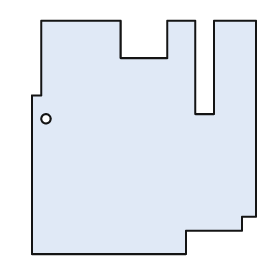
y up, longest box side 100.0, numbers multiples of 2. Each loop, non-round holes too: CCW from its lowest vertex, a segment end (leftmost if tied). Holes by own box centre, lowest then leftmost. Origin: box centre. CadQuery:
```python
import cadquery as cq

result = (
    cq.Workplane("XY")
    .moveTo(-48.0, -50.0)
    .lineTo(18.0, -50.0)
    .lineTo(18.0, -40.0)
    .lineTo(42.0, -40.0)
    .lineTo(42.0, -34.0)
    .lineTo(48.0, -34.0)
    .lineTo(48.0, 50.0)
    .lineTo(30.0, 50.0)
    .lineTo(30.0, 10.0)
    .lineTo(22.0, 10.0)
    .lineTo(22.0, 50.0)
    .lineTo(10.0, 50.0)
    .lineTo(10.0, 34.0)
    .lineTo(-10.0, 34.0)
    .lineTo(-10.0, 50.0)
    .lineTo(-44.0, 50.0)
    .lineTo(-44.0, 18.0)
    .lineTo(-48.0, 18.0)
    .close()
    .moveTo(-42.0, 8.0)
    .circle(2.0)
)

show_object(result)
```